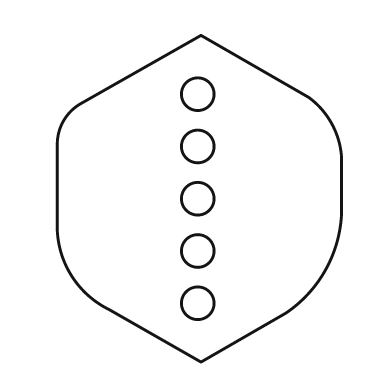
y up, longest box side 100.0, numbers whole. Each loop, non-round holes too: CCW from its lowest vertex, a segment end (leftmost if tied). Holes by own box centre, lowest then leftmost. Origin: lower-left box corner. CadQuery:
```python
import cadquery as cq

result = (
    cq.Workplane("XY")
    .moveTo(44.0, 0.0)
    .lineTo(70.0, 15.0)
    .threePointArc((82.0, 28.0), (87.0, 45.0))
    .lineTo(87.0, 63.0)
    .threePointArc((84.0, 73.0), (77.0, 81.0))
    .lineTo(44.0, 100.0)
    .lineTo(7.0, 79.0)
    .threePointArc((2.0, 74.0), (0.0, 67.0))
    .lineTo(0.0, 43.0)
    .threePointArc((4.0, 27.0), (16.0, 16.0))
    .close()
    .moveTo(43.0, 18.0)
    .circle(5.0)
    .moveTo(43.0, 34.0)
    .circle(5.0)
    .moveTo(43.0, 50.0)
    .circle(5.0)
    .moveTo(43.0, 66.0)
    .circle(5.0)
    .moveTo(43.0, 82.0)
    .circle(5.0)
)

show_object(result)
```